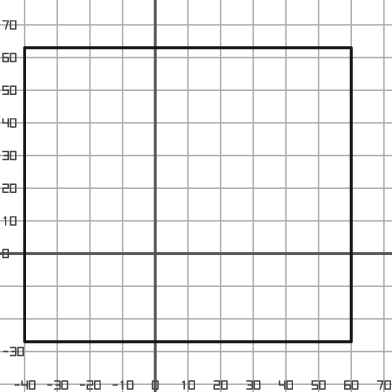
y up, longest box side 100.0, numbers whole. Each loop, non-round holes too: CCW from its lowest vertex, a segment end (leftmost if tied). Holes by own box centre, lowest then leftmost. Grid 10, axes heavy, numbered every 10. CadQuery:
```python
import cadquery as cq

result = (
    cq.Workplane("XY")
    .moveTo(-40.0, -27.0)
    .lineTo(60.0, -27.0)
    .lineTo(60.0, 63.0)
    .lineTo(-40.0, 63.0)
    .close()
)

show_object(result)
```